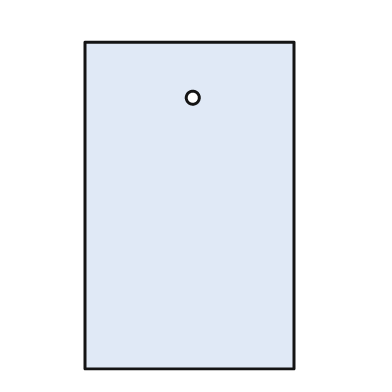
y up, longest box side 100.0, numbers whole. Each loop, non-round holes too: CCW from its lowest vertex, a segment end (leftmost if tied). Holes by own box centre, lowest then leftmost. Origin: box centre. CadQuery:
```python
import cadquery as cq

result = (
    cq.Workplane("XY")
    .moveTo(-32.0, -50.0)
    .lineTo(32.0, -50.0)
    .lineTo(32.0, 50.0)
    .lineTo(-32.0, 50.0)
    .close()
    .moveTo(1.0, 33.0)
    .circle(2.0)
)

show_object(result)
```